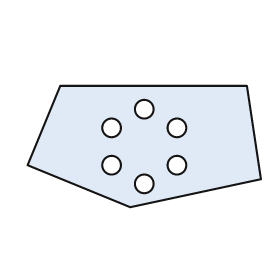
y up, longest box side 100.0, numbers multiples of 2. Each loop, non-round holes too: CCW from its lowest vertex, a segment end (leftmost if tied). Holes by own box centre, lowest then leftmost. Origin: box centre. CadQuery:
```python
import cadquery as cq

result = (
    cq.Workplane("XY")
    .moveTo(-6.0, -26.0)
    .lineTo(50.0, -14.0)
    .lineTo(44.0, 26.0)
    .lineTo(-36.0, 26.0)
    .lineTo(-50.0, -8.0)
    .close()
    .moveTo(0.0, -16.0)
    .circle(4.0)
    .moveTo(-14.0, -8.0)
    .circle(4.0)
    .moveTo(14.0, -8.0)
    .circle(4.0)
    .moveTo(-14.0, 8.0)
    .circle(4.0)
    .moveTo(14.0, 8.0)
    .circle(4.0)
    .moveTo(0.0, 16.0)
    .circle(4.0)
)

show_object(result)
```